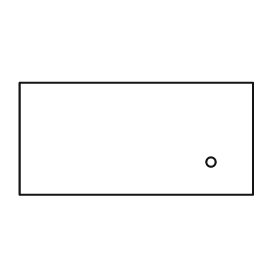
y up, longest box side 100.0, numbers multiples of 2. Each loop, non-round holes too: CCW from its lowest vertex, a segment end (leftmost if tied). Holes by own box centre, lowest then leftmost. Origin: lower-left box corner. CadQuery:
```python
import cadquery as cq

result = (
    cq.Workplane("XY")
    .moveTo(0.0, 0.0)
    .lineTo(100.0, 0.0)
    .lineTo(100.0, 48.0)
    .lineTo(0.0, 48.0)
    .close()
    .moveTo(82.0, 14.0)
    .circle(2.0)
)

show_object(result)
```